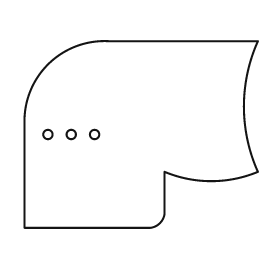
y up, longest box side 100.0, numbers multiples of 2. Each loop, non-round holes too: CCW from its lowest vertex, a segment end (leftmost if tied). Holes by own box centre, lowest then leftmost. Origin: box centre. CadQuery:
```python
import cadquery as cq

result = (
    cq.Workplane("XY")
    .moveTo(-50.0, -40.0)
    .lineTo(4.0, -40.0)
    .threePointArc((8.0, -38.0), (10.0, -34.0))
    .lineTo(10.0, -16.0)
    .threePointArc((30.0, -20.0), (50.0, -16.0))
    .threePointArc((44.0, 12.0), (50.0, 40.0))
    .lineTo(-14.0, 40.0)
    .threePointArc((-40.0, 30.0), (-50.0, 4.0))
    .close()
    .moveTo(-40.0, 0.0)
    .circle(2.0)
    .moveTo(-30.0, 0.0)
    .circle(2.0)
    .moveTo(-20.0, 0.0)
    .circle(2.0)
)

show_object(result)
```